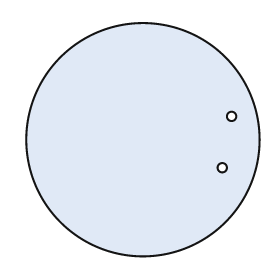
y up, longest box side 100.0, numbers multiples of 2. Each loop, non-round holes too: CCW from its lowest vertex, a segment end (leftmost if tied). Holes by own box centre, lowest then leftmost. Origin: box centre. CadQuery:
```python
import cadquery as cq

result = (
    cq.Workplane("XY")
    .moveTo(0.0, 0.0)
    .circle(50.0)
    .moveTo(34.0, -12.0)
    .circle(2.0)
    .moveTo(38.0, 10.0)
    .circle(2.0)
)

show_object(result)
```